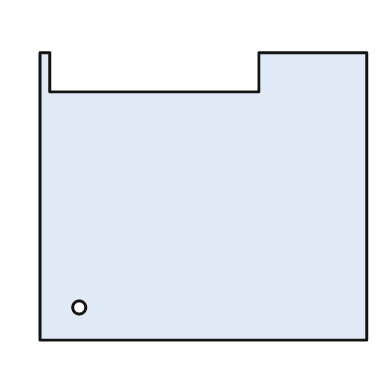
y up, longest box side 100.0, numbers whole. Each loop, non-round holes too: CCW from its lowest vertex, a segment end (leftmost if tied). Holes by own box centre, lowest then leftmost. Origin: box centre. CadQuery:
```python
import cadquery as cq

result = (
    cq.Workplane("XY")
    .moveTo(-50.0, -44.0)
    .lineTo(50.0, -44.0)
    .lineTo(50.0, 44.0)
    .lineTo(17.0, 44.0)
    .lineTo(17.0, 32.0)
    .lineTo(-47.0, 32.0)
    .lineTo(-47.0, 44.0)
    .lineTo(-50.0, 44.0)
    .close()
    .moveTo(-38.0, -34.0)
    .circle(2.0)
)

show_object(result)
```